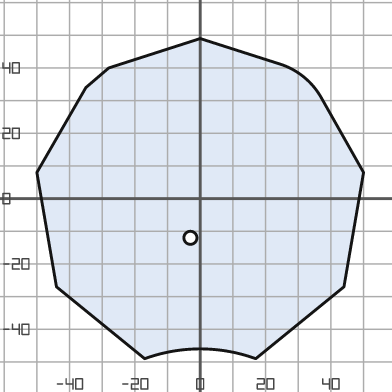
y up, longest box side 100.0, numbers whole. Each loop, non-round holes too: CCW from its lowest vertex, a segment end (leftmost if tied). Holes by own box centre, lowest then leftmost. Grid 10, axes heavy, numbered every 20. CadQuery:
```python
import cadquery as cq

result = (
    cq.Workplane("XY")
    .moveTo(-17.0, -49.0)
    .threePointArc((0.0, -46.0), (17.0, -49.0))
    .lineTo(44.0, -27.0)
    .lineTo(50.0, 8.0)
    .lineTo(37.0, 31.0)
    .threePointArc((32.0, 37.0), (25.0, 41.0))
    .lineTo(0.0, 49.0)
    .lineTo(-28.0, 40.0)
    .lineTo(-35.0, 34.0)
    .lineTo(-50.0, 8.0)
    .lineTo(-44.0, -27.0)
    .close()
    .moveTo(-3.0, -12.0)
    .circle(2.0)
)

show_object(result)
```